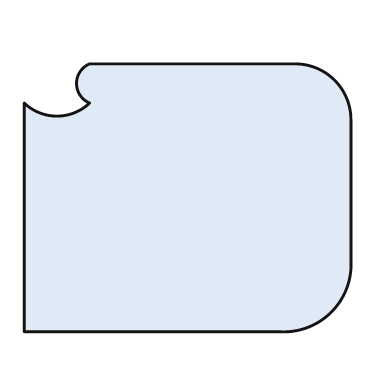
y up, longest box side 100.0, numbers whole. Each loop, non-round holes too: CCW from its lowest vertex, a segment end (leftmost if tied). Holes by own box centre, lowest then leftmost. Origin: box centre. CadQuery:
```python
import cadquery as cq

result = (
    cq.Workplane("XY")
    .moveTo(-50.0, -41.0)
    .lineTo(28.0, -41.0)
    .threePointArc((44.0, -35.0), (50.0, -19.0))
    .lineTo(50.0, 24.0)
    .threePointArc((45.0, 36.0), (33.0, 41.0))
    .lineTo(-30.0, 41.0)
    .threePointArc((-34.0, 35.0), (-30.0, 29.0))
    .threePointArc((-40.0, 25.0), (-50.0, 29.0))
    .close()
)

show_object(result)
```